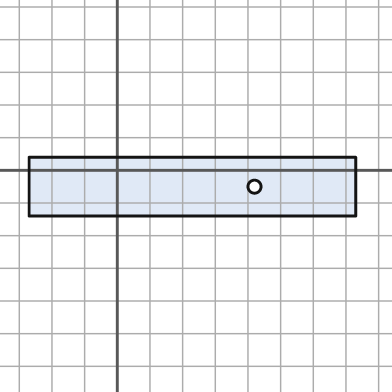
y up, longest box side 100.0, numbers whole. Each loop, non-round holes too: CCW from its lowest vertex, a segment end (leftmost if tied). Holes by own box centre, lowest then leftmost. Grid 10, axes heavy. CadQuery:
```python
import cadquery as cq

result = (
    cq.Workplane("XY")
    .moveTo(-27.0, -14.0)
    .lineTo(73.0, -14.0)
    .lineTo(73.0, 4.0)
    .lineTo(-27.0, 4.0)
    .close()
    .moveTo(42.0, -5.0)
    .circle(2.0)
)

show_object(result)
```